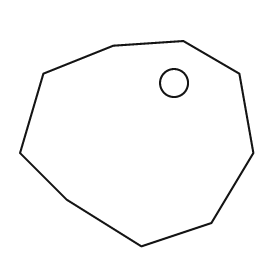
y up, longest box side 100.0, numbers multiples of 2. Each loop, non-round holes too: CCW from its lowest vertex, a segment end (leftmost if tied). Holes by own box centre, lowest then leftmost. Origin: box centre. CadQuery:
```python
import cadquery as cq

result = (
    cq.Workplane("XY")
    .moveTo(2.0, -44.0)
    .lineTo(32.0, -34.0)
    .lineTo(50.0, -4.0)
    .lineTo(44.0, 30.0)
    .lineTo(20.0, 44.0)
    .lineTo(-10.0, 42.0)
    .lineTo(-40.0, 30.0)
    .lineTo(-50.0, -4.0)
    .lineTo(-30.0, -24.0)
    .close()
    .moveTo(16.0, 26.0)
    .circle(6.0)
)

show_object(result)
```